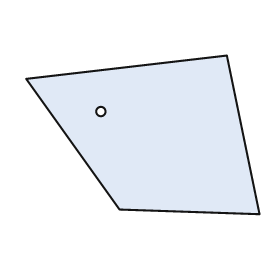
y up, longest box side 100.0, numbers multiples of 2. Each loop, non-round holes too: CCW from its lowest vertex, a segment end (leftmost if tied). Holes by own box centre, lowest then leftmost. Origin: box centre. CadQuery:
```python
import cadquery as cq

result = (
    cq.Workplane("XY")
    .moveTo(50.0, -34.0)
    .lineTo(36.0, 34.0)
    .lineTo(-50.0, 24.0)
    .lineTo(-10.0, -32.0)
    .close()
    .moveTo(-18.0, 10.0)
    .circle(2.0)
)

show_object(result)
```